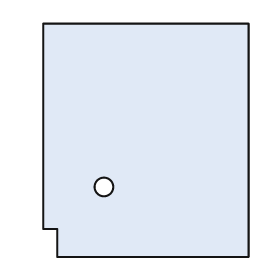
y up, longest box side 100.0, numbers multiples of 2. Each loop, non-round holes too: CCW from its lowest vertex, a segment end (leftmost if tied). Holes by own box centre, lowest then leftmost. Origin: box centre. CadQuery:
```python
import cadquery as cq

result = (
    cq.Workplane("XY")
    .moveTo(-38.0, -50.0)
    .lineTo(44.0, -50.0)
    .lineTo(44.0, 50.0)
    .lineTo(-44.0, 50.0)
    .lineTo(-44.0, -38.0)
    .lineTo(-38.0, -38.0)
    .close()
    .moveTo(-18.0, -20.0)
    .circle(4.0)
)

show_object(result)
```